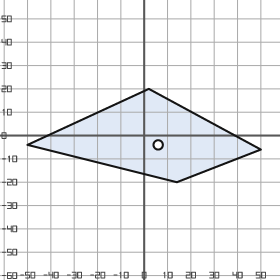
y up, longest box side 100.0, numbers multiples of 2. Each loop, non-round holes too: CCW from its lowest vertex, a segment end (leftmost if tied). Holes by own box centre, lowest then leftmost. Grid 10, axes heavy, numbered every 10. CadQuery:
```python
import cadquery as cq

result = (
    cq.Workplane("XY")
    .moveTo(14.0, -20.0)
    .lineTo(50.0, -6.0)
    .lineTo(2.0, 20.0)
    .lineTo(-50.0, -4.0)
    .close()
    .moveTo(6.0, -4.0)
    .circle(2.0)
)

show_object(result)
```